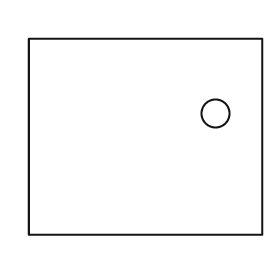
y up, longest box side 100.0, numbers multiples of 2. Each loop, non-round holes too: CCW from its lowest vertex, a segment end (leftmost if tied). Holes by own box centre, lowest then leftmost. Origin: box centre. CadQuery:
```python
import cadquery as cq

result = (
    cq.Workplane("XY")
    .moveTo(-50.0, -42.0)
    .lineTo(50.0, -42.0)
    .lineTo(50.0, 42.0)
    .lineTo(-50.0, 42.0)
    .close()
    .moveTo(30.0, 10.0)
    .circle(6.0)
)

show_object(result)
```